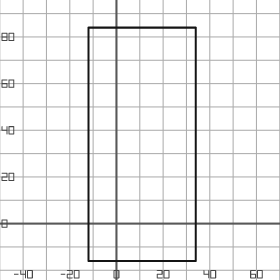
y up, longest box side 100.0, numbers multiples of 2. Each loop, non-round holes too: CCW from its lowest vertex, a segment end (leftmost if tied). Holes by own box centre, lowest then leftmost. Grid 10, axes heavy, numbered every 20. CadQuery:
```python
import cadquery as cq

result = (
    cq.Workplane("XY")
    .moveTo(-12.0, -16.0)
    .lineTo(34.0, -16.0)
    .lineTo(34.0, 84.0)
    .lineTo(-12.0, 84.0)
    .close()
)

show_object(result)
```